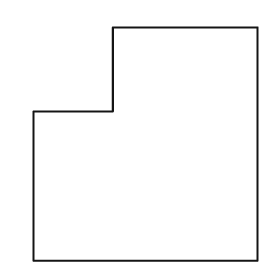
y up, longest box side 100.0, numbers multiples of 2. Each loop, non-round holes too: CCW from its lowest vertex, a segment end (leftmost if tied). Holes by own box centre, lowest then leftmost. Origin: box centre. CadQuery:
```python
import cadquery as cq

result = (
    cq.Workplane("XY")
    .moveTo(-48.0, -50.0)
    .lineTo(48.0, -50.0)
    .lineTo(48.0, 50.0)
    .lineTo(-14.0, 50.0)
    .lineTo(-14.0, 14.0)
    .lineTo(-48.0, 14.0)
    .close()
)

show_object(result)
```